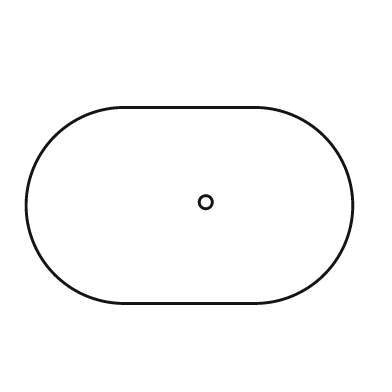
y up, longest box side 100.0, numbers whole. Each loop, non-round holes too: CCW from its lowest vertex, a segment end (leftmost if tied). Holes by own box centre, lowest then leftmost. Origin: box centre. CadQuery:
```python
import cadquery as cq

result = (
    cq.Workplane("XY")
    .moveTo(-20.0, -30.0)
    .lineTo(20.0, -30.0)
    .threePointArc((50.0, 0.0), (20.0, 30.0))
    .lineTo(-20.0, 30.0)
    .threePointArc((-50.0, 0.0), (-20.0, -30.0))
    .close()
    .moveTo(5.0, 1.0)
    .circle(2.0)
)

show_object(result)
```